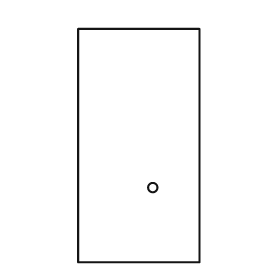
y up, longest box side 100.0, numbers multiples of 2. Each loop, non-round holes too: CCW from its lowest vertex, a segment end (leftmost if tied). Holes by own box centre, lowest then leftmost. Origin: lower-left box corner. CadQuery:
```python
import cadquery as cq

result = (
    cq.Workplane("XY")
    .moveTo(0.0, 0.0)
    .lineTo(52.0, 0.0)
    .lineTo(52.0, 100.0)
    .lineTo(0.0, 100.0)
    .close()
    .moveTo(32.0, 32.0)
    .circle(2.0)
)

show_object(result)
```